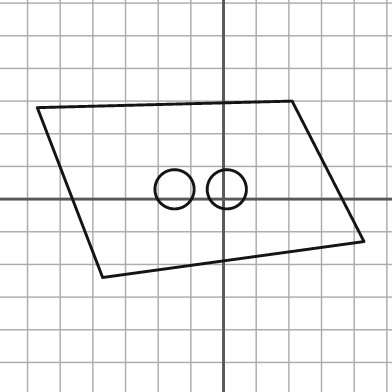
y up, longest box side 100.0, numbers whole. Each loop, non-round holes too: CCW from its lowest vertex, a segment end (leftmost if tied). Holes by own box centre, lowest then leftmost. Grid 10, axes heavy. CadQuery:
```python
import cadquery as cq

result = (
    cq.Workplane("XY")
    .moveTo(-37.0, -24.0)
    .lineTo(43.0, -13.0)
    .lineTo(21.0, 30.0)
    .lineTo(-57.0, 28.0)
    .close()
    .moveTo(-15.0, 3.0)
    .circle(6.0)
    .moveTo(1.0, 3.0)
    .circle(6.0)
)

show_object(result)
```